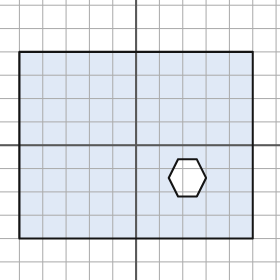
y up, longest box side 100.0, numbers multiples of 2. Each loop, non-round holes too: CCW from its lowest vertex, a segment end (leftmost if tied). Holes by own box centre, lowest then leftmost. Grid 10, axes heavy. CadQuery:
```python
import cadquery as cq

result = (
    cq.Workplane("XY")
    .moveTo(-50.0, -40.0)
    .lineTo(50.0, -40.0)
    .lineTo(50.0, 40.0)
    .lineTo(-50.0, 40.0)
    .close()
    .moveTo(18.0, -22.0)
    .lineTo(26.0, -22.0)
    .lineTo(30.0, -14.0)
    .lineTo(26.0, -6.0)
    .lineTo(18.0, -6.0)
    .lineTo(14.0, -14.0)
    .close()
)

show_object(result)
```